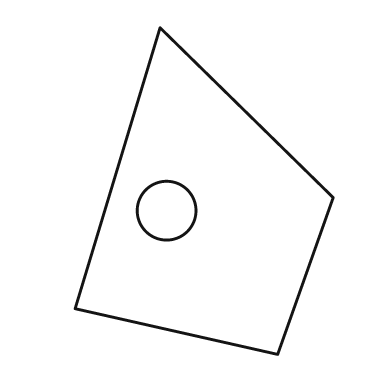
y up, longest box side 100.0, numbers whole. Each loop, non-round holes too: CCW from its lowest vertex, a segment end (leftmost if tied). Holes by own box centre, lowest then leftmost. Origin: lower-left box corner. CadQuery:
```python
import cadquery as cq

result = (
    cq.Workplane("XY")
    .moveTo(62.0, 0.0)
    .lineTo(79.0, 48.0)
    .lineTo(26.0, 100.0)
    .lineTo(0.0, 14.0)
    .close()
    .moveTo(28.0, 44.0)
    .circle(9.0)
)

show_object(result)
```